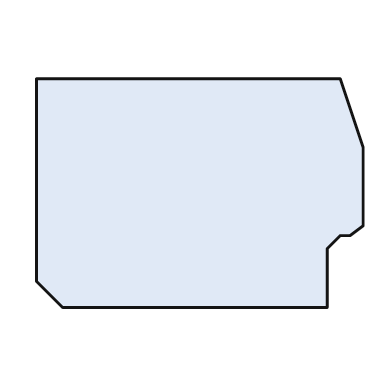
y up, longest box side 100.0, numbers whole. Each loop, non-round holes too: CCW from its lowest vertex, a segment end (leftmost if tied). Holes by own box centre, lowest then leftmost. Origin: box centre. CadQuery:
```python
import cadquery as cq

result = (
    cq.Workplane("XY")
    .moveTo(-42.0, -35.0)
    .lineTo(39.0, -35.0)
    .lineTo(39.0, -17.0)
    .lineTo(43.0, -13.0)
    .lineTo(46.0, -13.0)
    .lineTo(50.0, -10.0)
    .lineTo(50.0, 14.0)
    .lineTo(43.0, 35.0)
    .lineTo(-50.0, 35.0)
    .lineTo(-50.0, -27.0)
    .close()
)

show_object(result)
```